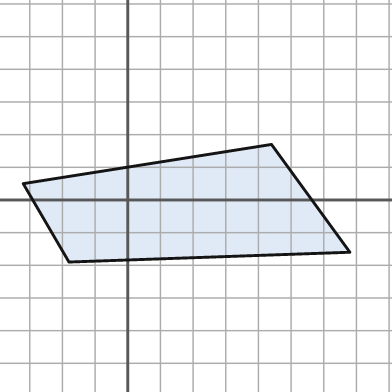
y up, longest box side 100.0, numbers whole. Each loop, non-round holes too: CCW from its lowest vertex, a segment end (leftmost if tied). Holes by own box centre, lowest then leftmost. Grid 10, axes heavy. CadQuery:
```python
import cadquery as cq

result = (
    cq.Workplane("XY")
    .moveTo(-18.0, -19.0)
    .lineTo(68.0, -16.0)
    .lineTo(44.0, 17.0)
    .lineTo(-32.0, 5.0)
    .close()
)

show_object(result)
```